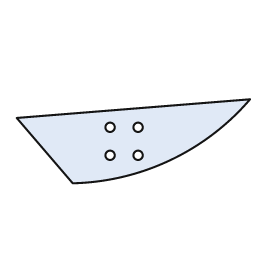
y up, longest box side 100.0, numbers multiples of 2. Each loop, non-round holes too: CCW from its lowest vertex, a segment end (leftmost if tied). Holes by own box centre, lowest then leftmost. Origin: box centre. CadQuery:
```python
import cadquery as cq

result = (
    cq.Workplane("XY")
    .moveTo(-26.0, -18.0)
    .threePointArc((16.0, -8.0), (50.0, 18.0))
    .lineTo(-50.0, 10.0)
    .close()
    .moveTo(-10.0, -6.0)
    .circle(2.0)
    .moveTo(2.0, -6.0)
    .circle(2.0)
    .moveTo(-10.0, 6.0)
    .circle(2.0)
    .moveTo(2.0, 6.0)
    .circle(2.0)
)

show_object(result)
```